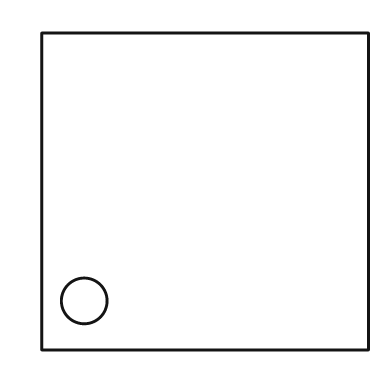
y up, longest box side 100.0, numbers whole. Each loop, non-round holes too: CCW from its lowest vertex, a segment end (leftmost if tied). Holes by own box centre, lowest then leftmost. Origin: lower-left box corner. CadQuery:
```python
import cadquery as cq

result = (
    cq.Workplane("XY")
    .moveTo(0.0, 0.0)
    .lineTo(100.0, 0.0)
    .lineTo(100.0, 97.0)
    .lineTo(0.0, 97.0)
    .close()
    .moveTo(13.0, 15.0)
    .circle(7.0)
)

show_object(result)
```